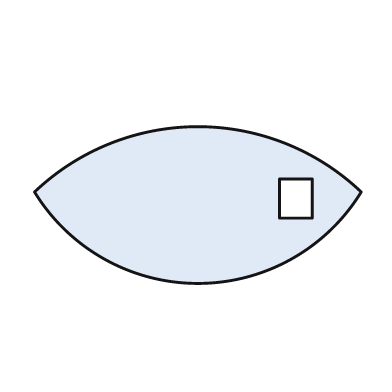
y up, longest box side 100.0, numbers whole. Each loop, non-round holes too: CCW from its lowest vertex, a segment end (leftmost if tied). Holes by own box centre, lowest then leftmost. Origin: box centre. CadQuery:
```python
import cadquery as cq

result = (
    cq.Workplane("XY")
    .moveTo(-50.0, 4.0)
    .threePointArc((0.0, -24.0), (50.0, 4.0))
    .threePointArc((0.0, 24.0), (-50.0, 4.0))
    .close()
    .moveTo(25.0, -4.0)
    .lineTo(35.0, -4.0)
    .lineTo(35.0, 8.0)
    .lineTo(25.0, 8.0)
    .close()
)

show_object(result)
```